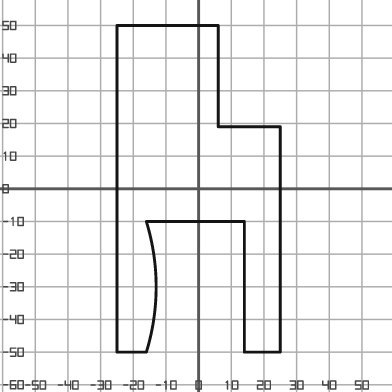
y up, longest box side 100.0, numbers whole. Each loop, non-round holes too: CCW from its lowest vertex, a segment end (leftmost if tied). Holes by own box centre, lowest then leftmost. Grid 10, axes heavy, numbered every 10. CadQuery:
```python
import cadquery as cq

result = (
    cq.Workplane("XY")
    .moveTo(-25.0, -50.0)
    .lineTo(-16.0, -50.0)
    .threePointArc((-13.0, -30.0), (-16.0, -10.0))
    .lineTo(14.0, -10.0)
    .lineTo(14.0, -50.0)
    .lineTo(25.0, -50.0)
    .lineTo(25.0, 19.0)
    .lineTo(6.0, 19.0)
    .lineTo(6.0, 50.0)
    .lineTo(-25.0, 50.0)
    .close()
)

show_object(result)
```